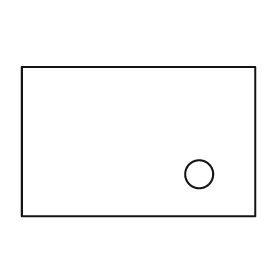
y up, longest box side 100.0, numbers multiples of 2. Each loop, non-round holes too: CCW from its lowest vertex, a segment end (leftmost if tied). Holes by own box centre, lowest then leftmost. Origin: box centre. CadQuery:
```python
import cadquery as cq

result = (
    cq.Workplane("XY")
    .moveTo(-50.0, -32.0)
    .lineTo(50.0, -32.0)
    .lineTo(50.0, 32.0)
    .lineTo(-50.0, 32.0)
    .close()
    .moveTo(26.0, -14.0)
    .circle(6.0)
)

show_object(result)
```